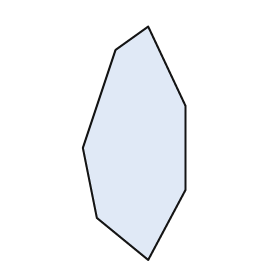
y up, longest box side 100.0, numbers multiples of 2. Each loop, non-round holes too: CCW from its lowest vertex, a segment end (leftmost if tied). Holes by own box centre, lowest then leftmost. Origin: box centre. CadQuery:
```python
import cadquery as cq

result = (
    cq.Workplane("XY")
    .moveTo(6.0, -50.0)
    .lineTo(22.0, -20.0)
    .lineTo(22.0, 16.0)
    .lineTo(6.0, 50.0)
    .lineTo(-8.0, 40.0)
    .lineTo(-22.0, -2.0)
    .lineTo(-16.0, -32.0)
    .close()
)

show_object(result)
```